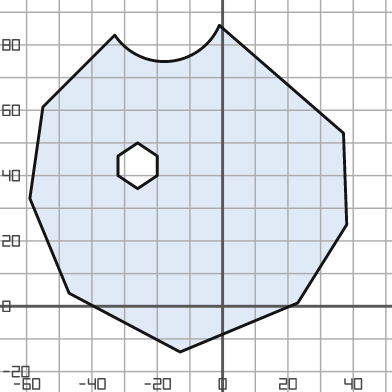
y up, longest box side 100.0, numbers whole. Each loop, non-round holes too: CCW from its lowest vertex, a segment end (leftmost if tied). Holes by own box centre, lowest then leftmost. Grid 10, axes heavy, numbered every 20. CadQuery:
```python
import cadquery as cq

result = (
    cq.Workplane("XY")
    .moveTo(-13.0, -14.0)
    .lineTo(23.0, 1.0)
    .lineTo(38.0, 25.0)
    .lineTo(37.0, 53.0)
    .lineTo(-1.0, 86.0)
    .threePointArc((-16.0, 75.0), (-33.0, 83.0))
    .lineTo(-55.0, 61.0)
    .lineTo(-59.0, 33.0)
    .lineTo(-47.0, 4.0)
    .close()
    .moveTo(-26.0, 36.0)
    .lineTo(-20.0, 40.0)
    .lineTo(-20.0, 46.0)
    .lineTo(-26.0, 50.0)
    .lineTo(-32.0, 46.0)
    .lineTo(-32.0, 40.0)
    .close()
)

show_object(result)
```